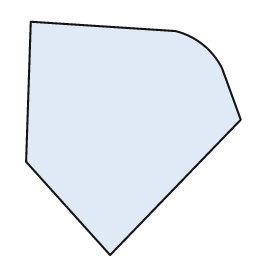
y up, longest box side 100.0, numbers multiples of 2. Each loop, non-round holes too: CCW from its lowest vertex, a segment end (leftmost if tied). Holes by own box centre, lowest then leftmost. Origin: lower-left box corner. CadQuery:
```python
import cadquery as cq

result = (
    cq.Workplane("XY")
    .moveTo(36.0, 0.0)
    .lineTo(92.0, 58.0)
    .lineTo(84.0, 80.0)
    .threePointArc((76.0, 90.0), (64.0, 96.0))
    .lineTo(2.0, 100.0)
    .lineTo(0.0, 40.0)
    .close()
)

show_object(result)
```